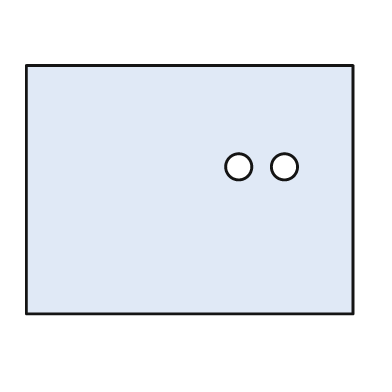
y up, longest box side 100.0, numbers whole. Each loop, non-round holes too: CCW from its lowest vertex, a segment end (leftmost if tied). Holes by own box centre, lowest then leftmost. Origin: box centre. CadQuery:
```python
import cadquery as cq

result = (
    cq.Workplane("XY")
    .moveTo(-50.0, -38.0)
    .lineTo(50.0, -38.0)
    .lineTo(50.0, 38.0)
    .lineTo(-50.0, 38.0)
    .close()
    .moveTo(15.0, 7.0)
    .circle(4.0)
    .moveTo(29.0, 7.0)
    .circle(4.0)
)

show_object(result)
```